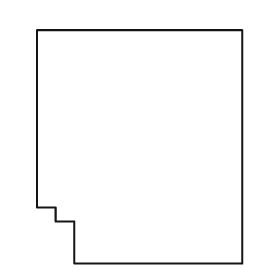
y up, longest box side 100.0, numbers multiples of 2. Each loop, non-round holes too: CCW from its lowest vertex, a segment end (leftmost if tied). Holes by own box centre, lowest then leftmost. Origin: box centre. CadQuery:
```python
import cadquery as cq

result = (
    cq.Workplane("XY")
    .moveTo(-28.0, -50.0)
    .lineTo(44.0, -50.0)
    .lineTo(44.0, 50.0)
    .lineTo(-44.0, 50.0)
    .lineTo(-44.0, -26.0)
    .lineTo(-36.0, -26.0)
    .lineTo(-36.0, -32.0)
    .lineTo(-28.0, -32.0)
    .close()
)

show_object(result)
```